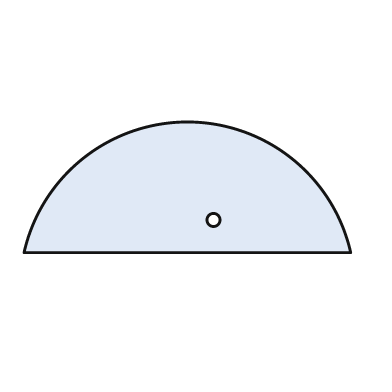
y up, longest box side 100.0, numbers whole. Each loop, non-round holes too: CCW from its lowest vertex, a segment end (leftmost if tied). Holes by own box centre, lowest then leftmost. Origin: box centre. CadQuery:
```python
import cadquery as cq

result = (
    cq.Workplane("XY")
    .moveTo(-50.0, -20.0)
    .lineTo(50.0, -20.0)
    .threePointArc((0.0, 20.0), (-50.0, -20.0))
    .close()
    .moveTo(8.0, -10.0)
    .circle(2.0)
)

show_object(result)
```